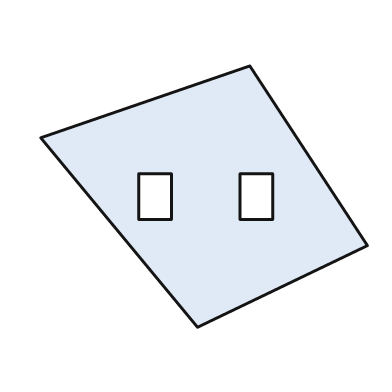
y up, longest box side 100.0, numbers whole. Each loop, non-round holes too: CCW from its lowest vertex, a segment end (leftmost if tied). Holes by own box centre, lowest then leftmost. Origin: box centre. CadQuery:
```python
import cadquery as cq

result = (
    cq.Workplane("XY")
    .moveTo(-2.0, -40.0)
    .lineTo(50.0, -15.0)
    .lineTo(14.0, 40.0)
    .lineTo(-50.0, 18.0)
    .close()
    .moveTo(-20.0, -7.0)
    .lineTo(-10.0, -7.0)
    .lineTo(-10.0, 7.0)
    .lineTo(-20.0, 7.0)
    .close()
    .moveTo(11.0, -7.0)
    .lineTo(21.0, -7.0)
    .lineTo(21.0, 7.0)
    .lineTo(11.0, 7.0)
    .close()
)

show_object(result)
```